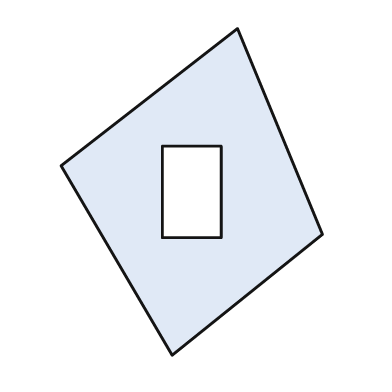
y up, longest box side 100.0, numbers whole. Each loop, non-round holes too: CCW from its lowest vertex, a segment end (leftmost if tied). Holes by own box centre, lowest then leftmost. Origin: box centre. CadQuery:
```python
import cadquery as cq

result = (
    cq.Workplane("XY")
    .moveTo(-6.0, -50.0)
    .lineTo(40.0, -13.0)
    .lineTo(14.0, 50.0)
    .lineTo(-40.0, 8.0)
    .close()
    .moveTo(-9.0, -14.0)
    .lineTo(9.0, -14.0)
    .lineTo(9.0, 14.0)
    .lineTo(-9.0, 14.0)
    .close()
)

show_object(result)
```